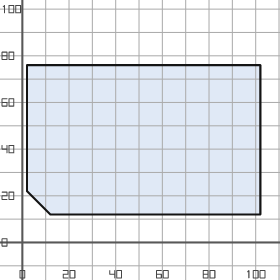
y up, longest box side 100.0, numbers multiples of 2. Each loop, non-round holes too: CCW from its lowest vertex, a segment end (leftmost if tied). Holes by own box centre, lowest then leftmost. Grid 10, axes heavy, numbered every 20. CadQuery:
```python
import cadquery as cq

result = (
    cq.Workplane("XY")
    .moveTo(12.0, 12.0)
    .lineTo(102.0, 12.0)
    .lineTo(102.0, 76.0)
    .lineTo(2.0, 76.0)
    .lineTo(2.0, 22.0)
    .close()
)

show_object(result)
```